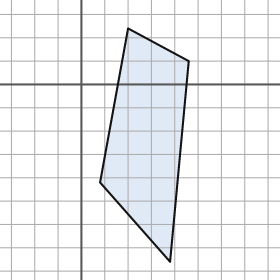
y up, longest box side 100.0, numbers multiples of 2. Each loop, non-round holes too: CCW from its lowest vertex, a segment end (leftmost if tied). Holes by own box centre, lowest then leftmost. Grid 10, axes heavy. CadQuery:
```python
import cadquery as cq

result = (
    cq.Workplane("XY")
    .moveTo(38.0, -76.0)
    .lineTo(46.0, 10.0)
    .lineTo(20.0, 24.0)
    .lineTo(8.0, -42.0)
    .close()
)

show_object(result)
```